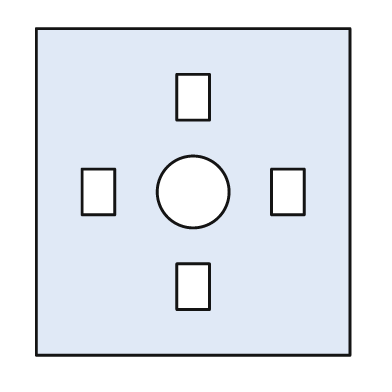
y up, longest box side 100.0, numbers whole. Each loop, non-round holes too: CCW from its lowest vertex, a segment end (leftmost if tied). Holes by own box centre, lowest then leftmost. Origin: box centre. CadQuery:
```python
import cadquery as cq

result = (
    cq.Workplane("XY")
    .moveTo(-48.0, -50.0)
    .lineTo(48.0, -50.0)
    .lineTo(48.0, 50.0)
    .lineTo(-48.0, 50.0)
    .close()
    .moveTo(-5.0, -36.0)
    .lineTo(5.0, -36.0)
    .lineTo(5.0, -22.0)
    .lineTo(-5.0, -22.0)
    .close()
    .moveTo(-34.0, -7.0)
    .lineTo(-24.0, -7.0)
    .lineTo(-24.0, 7.0)
    .lineTo(-34.0, 7.0)
    .close()
    .moveTo(0.0, 0.0)
    .circle(11.0)
    .moveTo(24.0, -7.0)
    .lineTo(34.0, -7.0)
    .lineTo(34.0, 7.0)
    .lineTo(24.0, 7.0)
    .close()
    .moveTo(-5.0, 22.0)
    .lineTo(5.0, 22.0)
    .lineTo(5.0, 36.0)
    .lineTo(-5.0, 36.0)
    .close()
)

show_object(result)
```